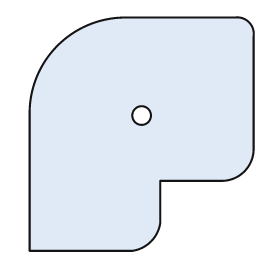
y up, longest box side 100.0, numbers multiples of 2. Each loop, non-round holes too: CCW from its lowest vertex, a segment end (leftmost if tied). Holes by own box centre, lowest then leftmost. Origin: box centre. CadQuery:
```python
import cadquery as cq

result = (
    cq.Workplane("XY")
    .moveTo(-48.0, -50.0)
    .lineTo(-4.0, -50.0)
    .threePointArc((4.0, -46.0), (8.0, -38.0))
    .lineTo(8.0, -20.0)
    .lineTo(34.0, -20.0)
    .threePointArc((44.0, -16.0), (48.0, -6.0))
    .lineTo(48.0, 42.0)
    .threePointArc((46.0, 48.0), (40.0, 50.0))
    .lineTo(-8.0, 50.0)
    .threePointArc((-36.0, 38.0), (-48.0, 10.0))
    .close()
    .moveTo(0.0, 8.0)
    .circle(4.0)
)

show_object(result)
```